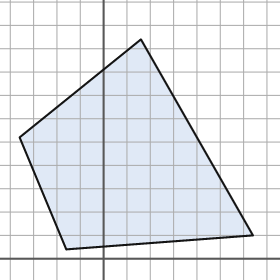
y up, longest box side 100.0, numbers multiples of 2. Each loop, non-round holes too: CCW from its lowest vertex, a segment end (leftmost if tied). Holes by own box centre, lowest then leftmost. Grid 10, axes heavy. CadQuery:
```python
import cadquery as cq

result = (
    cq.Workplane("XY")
    .moveTo(-16.0, 4.0)
    .lineTo(64.0, 10.0)
    .lineTo(16.0, 94.0)
    .lineTo(-36.0, 52.0)
    .close()
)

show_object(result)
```